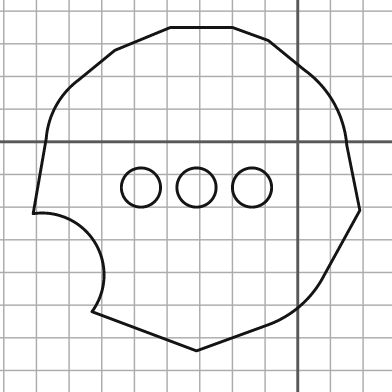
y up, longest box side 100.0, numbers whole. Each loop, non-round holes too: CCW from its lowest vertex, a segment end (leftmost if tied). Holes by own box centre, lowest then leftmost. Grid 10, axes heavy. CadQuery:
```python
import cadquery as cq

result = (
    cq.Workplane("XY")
    .moveTo(-31.0, -64.0)
    .lineTo(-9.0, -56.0)
    .threePointArc((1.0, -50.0), (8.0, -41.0))
    .lineTo(19.0, -21.0)
    .lineTo(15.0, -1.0)
    .threePointArc((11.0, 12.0), (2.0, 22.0))
    .lineTo(-9.0, 31.0)
    .lineTo(-20.0, 35.0)
    .lineTo(-39.0, 35.0)
    .lineTo(-56.0, 28.0)
    .lineTo(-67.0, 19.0)
    .threePointArc((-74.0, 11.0), (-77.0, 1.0))
    .lineTo(-81.0, -22.0)
    .threePointArc((-62.0, -31.0), (-63.0, -52.0))
    .close()
    .moveTo(-48.0, -14.0)
    .circle(6.0)
    .moveTo(-31.0, -14.0)
    .circle(6.0)
    .moveTo(-14.0, -14.0)
    .circle(6.0)
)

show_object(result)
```